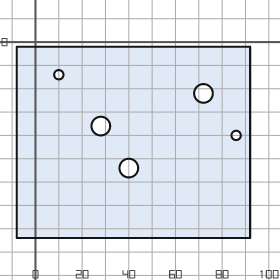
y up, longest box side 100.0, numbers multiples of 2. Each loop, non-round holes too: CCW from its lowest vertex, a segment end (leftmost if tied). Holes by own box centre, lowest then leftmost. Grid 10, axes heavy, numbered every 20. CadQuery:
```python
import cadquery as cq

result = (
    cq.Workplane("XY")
    .moveTo(-8.0, -84.0)
    .lineTo(92.0, -84.0)
    .lineTo(92.0, -2.0)
    .lineTo(-8.0, -2.0)
    .close()
    .moveTo(40.0, -54.0)
    .circle(4.0)
    .moveTo(86.0, -40.0)
    .circle(2.0)
    .moveTo(28.0, -36.0)
    .circle(4.0)
    .moveTo(72.0, -22.0)
    .circle(4.0)
    .moveTo(10.0, -14.0)
    .circle(2.0)
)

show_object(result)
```